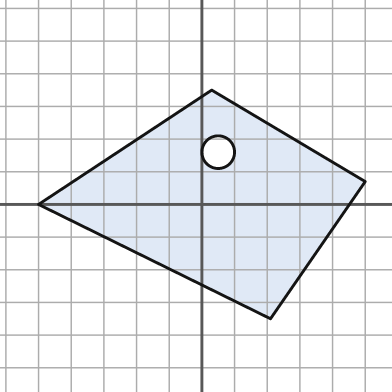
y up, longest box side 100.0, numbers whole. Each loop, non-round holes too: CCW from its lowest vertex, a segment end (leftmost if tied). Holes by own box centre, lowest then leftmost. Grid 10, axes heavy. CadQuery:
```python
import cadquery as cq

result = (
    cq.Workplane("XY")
    .moveTo(21.0, -35.0)
    .lineTo(50.0, 7.0)
    .lineTo(3.0, 35.0)
    .lineTo(-50.0, 0.0)
    .close()
    .moveTo(5.0, 16.0)
    .circle(5.0)
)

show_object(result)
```